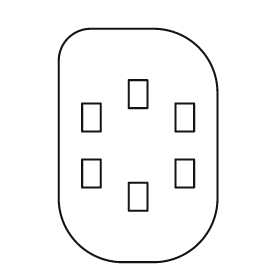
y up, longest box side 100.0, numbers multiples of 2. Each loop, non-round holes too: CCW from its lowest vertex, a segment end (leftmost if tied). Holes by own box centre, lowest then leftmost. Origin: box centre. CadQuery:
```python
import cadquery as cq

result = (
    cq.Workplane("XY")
    .moveTo(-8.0, -50.0)
    .lineTo(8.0, -50.0)
    .threePointArc((26.0, -42.0), (34.0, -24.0))
    .lineTo(34.0, 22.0)
    .threePointArc((26.0, 42.0), (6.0, 50.0))
    .lineTo(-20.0, 50.0)
    .threePointArc((-30.0, 46.0), (-34.0, 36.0))
    .lineTo(-34.0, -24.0)
    .threePointArc((-26.0, -42.0), (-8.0, -50.0))
    .close()
    .moveTo(-4.0, -28.0)
    .lineTo(4.0, -28.0)
    .lineTo(4.0, -16.0)
    .lineTo(-4.0, -16.0)
    .close()
    .moveTo(-24.0, -18.0)
    .lineTo(-16.0, -18.0)
    .lineTo(-16.0, -6.0)
    .lineTo(-24.0, -6.0)
    .close()
    .moveTo(16.0, -18.0)
    .lineTo(24.0, -18.0)
    .lineTo(24.0, -6.0)
    .lineTo(16.0, -6.0)
    .close()
    .moveTo(-24.0, 6.0)
    .lineTo(-16.0, 6.0)
    .lineTo(-16.0, 18.0)
    .lineTo(-24.0, 18.0)
    .close()
    .moveTo(16.0, 6.0)
    .lineTo(24.0, 6.0)
    .lineTo(24.0, 18.0)
    .lineTo(16.0, 18.0)
    .close()
    .moveTo(-4.0, 16.0)
    .lineTo(4.0, 16.0)
    .lineTo(4.0, 28.0)
    .lineTo(-4.0, 28.0)
    .close()
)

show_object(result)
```